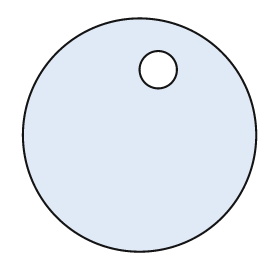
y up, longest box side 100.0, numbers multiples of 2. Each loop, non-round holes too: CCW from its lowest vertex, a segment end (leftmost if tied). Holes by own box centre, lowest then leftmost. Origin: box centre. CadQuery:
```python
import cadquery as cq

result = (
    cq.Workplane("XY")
    .moveTo(0.0, 0.0)
    .circle(50.0)
    .moveTo(8.0, 28.0)
    .circle(8.0)
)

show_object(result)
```